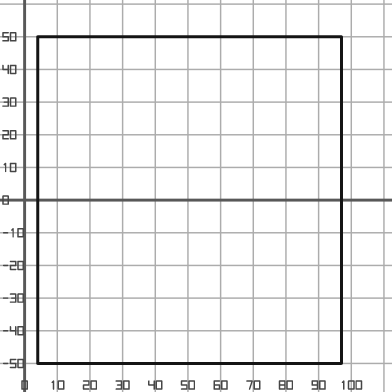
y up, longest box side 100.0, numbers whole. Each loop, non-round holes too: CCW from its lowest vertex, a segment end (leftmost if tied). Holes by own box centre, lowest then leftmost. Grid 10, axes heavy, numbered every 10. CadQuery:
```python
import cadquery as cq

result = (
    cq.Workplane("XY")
    .moveTo(4.0, -50.0)
    .lineTo(97.0, -50.0)
    .lineTo(97.0, 50.0)
    .lineTo(4.0, 50.0)
    .close()
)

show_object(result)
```